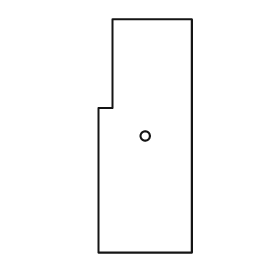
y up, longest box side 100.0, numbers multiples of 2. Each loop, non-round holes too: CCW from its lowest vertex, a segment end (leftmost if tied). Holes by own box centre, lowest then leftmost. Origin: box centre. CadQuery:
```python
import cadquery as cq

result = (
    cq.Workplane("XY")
    .moveTo(-20.0, -50.0)
    .lineTo(20.0, -50.0)
    .lineTo(20.0, 50.0)
    .lineTo(-14.0, 50.0)
    .lineTo(-14.0, 12.0)
    .lineTo(-20.0, 12.0)
    .close()
    .moveTo(0.0, 0.0)
    .circle(2.0)
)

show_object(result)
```